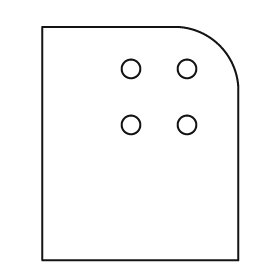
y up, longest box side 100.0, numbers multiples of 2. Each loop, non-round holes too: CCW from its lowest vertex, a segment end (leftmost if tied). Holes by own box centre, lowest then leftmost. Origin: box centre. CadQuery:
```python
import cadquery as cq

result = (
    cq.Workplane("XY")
    .moveTo(-42.0, -50.0)
    .lineTo(42.0, -50.0)
    .lineTo(42.0, 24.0)
    .threePointArc((34.0, 42.0), (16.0, 50.0))
    .lineTo(-42.0, 50.0)
    .close()
    .moveTo(-4.0, 8.0)
    .circle(4.0)
    .moveTo(20.0, 8.0)
    .circle(4.0)
    .moveTo(-4.0, 32.0)
    .circle(4.0)
    .moveTo(20.0, 32.0)
    .circle(4.0)
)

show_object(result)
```